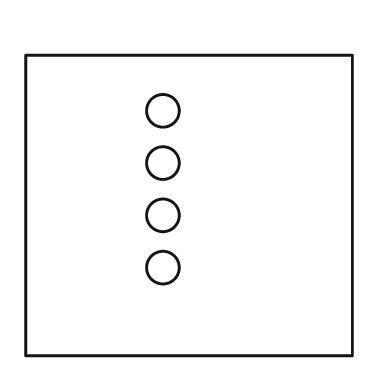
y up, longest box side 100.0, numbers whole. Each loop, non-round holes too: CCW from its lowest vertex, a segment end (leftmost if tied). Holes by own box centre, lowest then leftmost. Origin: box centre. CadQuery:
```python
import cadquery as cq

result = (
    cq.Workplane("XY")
    .moveTo(-50.0, -46.0)
    .lineTo(50.0, -46.0)
    .lineTo(50.0, 46.0)
    .lineTo(-50.0, 46.0)
    .close()
    .moveTo(-8.0, -19.0)
    .circle(5.0)
    .moveTo(-8.0, -3.0)
    .circle(5.0)
    .moveTo(-8.0, 13.0)
    .circle(5.0)
    .moveTo(-8.0, 29.0)
    .circle(5.0)
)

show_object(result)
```